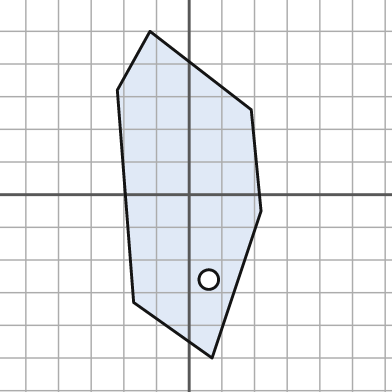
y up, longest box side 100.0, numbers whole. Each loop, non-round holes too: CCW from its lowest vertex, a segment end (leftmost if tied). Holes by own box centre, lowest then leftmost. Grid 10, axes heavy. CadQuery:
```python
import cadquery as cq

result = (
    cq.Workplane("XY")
    .moveTo(7.0, -50.0)
    .lineTo(22.0, -5.0)
    .lineTo(19.0, 26.0)
    .lineTo(-12.0, 50.0)
    .lineTo(-22.0, 32.0)
    .lineTo(-17.0, -33.0)
    .close()
    .moveTo(6.0, -26.0)
    .circle(3.0)
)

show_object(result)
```